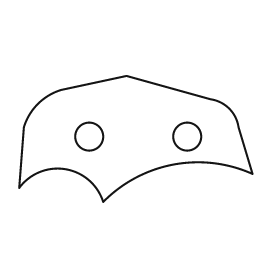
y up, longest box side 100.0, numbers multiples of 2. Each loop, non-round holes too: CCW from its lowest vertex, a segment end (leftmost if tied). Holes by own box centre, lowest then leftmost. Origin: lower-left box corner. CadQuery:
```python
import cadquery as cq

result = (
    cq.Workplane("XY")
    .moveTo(36.0, 0.0)
    .threePointArc((66.0, 16.0), (100.0, 12.0))
    .lineTo(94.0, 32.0)
    .threePointArc((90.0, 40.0), (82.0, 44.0))
    .lineTo(46.0, 54.0)
    .lineTo(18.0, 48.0)
    .threePointArc((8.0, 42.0), (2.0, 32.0))
    .lineTo(0.0, 6.0)
    .threePointArc((20.0, 14.0), (36.0, 0.0))
    .close()
    .moveTo(30.0, 28.0)
    .circle(6.0)
    .moveTo(72.0, 28.0)
    .circle(6.0)
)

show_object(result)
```